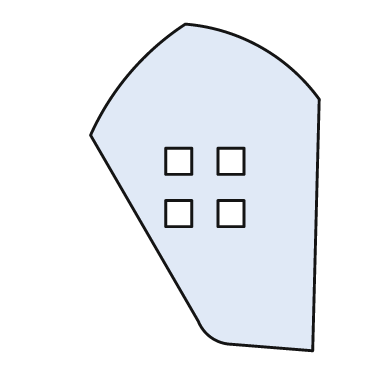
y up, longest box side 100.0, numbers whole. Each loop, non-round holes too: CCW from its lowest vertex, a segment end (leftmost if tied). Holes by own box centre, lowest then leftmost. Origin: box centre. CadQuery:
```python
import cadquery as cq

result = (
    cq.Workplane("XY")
    .moveTo(33.0, -50.0)
    .lineTo(35.0, 27.0)
    .threePointArc((17.0, 43.0), (-6.0, 50.0))
    .threePointArc((-23.0, 35.0), (-35.0, 16.0))
    .lineTo(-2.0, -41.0)
    .threePointArc((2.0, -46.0), (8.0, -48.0))
    .close()
    .moveTo(-12.0, -12.0)
    .lineTo(-4.0, -12.0)
    .lineTo(-4.0, -4.0)
    .lineTo(-12.0, -4.0)
    .close()
    .moveTo(4.0, -12.0)
    .lineTo(12.0, -12.0)
    .lineTo(12.0, -4.0)
    .lineTo(4.0, -4.0)
    .close()
    .moveTo(-12.0, 4.0)
    .lineTo(-4.0, 4.0)
    .lineTo(-4.0, 12.0)
    .lineTo(-12.0, 12.0)
    .close()
    .moveTo(4.0, 4.0)
    .lineTo(12.0, 4.0)
    .lineTo(12.0, 12.0)
    .lineTo(4.0, 12.0)
    .close()
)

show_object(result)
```